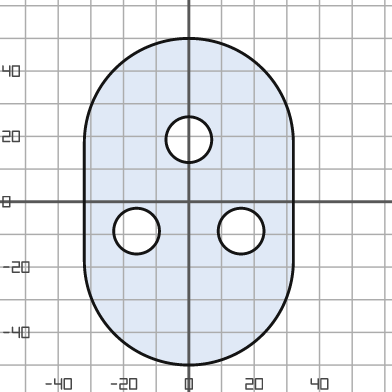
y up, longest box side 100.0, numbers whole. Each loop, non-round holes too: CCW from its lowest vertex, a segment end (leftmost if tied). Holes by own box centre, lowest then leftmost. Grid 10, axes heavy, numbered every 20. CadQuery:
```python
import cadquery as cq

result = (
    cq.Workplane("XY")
    .moveTo(-32.0, -18.0)
    .threePointArc((0.0, -50.0), (32.0, -18.0))
    .lineTo(32.0, 18.0)
    .threePointArc((0.0, 50.0), (-32.0, 18.0))
    .close()
    .moveTo(-16.0, -9.0)
    .circle(7.0)
    .moveTo(16.0, -9.0)
    .circle(7.0)
    .moveTo(0.0, 19.0)
    .circle(7.0)
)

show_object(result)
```